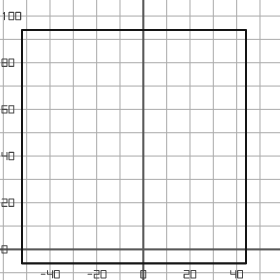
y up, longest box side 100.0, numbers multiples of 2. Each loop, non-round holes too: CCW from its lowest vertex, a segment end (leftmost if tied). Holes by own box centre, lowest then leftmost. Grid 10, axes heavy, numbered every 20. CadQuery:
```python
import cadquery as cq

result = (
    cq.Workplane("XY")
    .moveTo(-52.0, -6.0)
    .lineTo(44.0, -6.0)
    .lineTo(44.0, 94.0)
    .lineTo(-52.0, 94.0)
    .close()
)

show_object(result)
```